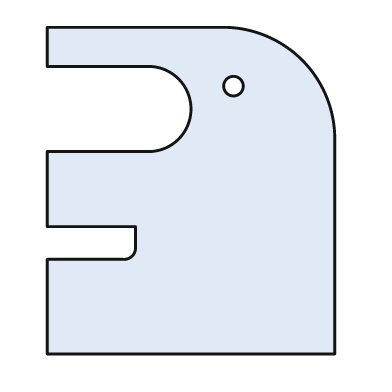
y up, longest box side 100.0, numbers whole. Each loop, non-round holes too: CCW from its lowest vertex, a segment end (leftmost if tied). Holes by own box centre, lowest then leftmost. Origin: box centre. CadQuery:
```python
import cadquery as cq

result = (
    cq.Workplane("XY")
    .moveTo(-44.0, -50.0)
    .lineTo(44.0, -50.0)
    .lineTo(44.0, 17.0)
    .threePointArc((34.0, 40.0), (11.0, 50.0))
    .lineTo(-44.0, 50.0)
    .lineTo(-44.0, 38.0)
    .lineTo(-12.0, 38.0)
    .threePointArc((0.0, 25.0), (-12.0, 12.0))
    .lineTo(-44.0, 12.0)
    .lineTo(-44.0, -11.0)
    .lineTo(-17.0, -11.0)
    .lineTo(-17.0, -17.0)
    .threePointArc((-18.0, -20.0), (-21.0, -21.0))
    .lineTo(-44.0, -21.0)
    .close()
    .moveTo(13.0, 32.0)
    .circle(3.0)
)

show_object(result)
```